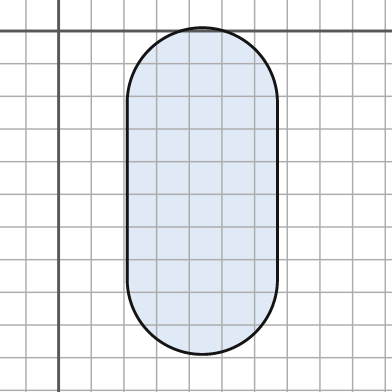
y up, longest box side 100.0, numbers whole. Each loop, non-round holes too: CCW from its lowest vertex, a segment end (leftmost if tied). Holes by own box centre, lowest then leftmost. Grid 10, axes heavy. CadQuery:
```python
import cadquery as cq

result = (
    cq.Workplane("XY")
    .moveTo(21.0, -76.0)
    .threePointArc((44.0, -99.0), (67.0, -76.0))
    .lineTo(67.0, -22.0)
    .threePointArc((44.0, 1.0), (21.0, -22.0))
    .close()
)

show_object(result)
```